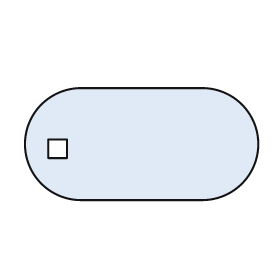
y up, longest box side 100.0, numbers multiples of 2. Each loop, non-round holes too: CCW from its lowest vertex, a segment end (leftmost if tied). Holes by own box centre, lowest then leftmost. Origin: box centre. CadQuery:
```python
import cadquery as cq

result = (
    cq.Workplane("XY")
    .moveTo(-26.0, -24.0)
    .lineTo(26.0, -24.0)
    .threePointArc((50.0, 0.0), (26.0, 24.0))
    .lineTo(-26.0, 24.0)
    .threePointArc((-50.0, 0.0), (-26.0, -24.0))
    .close()
    .moveTo(-40.0, -6.0)
    .lineTo(-32.0, -6.0)
    .lineTo(-32.0, 2.0)
    .lineTo(-40.0, 2.0)
    .close()
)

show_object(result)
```